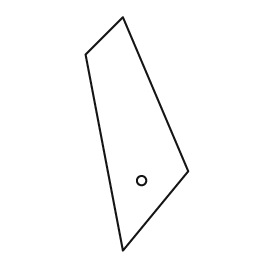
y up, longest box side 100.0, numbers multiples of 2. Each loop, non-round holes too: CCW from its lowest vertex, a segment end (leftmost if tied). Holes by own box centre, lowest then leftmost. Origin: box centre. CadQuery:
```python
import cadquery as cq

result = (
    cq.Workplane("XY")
    .moveTo(-6.0, -50.0)
    .lineTo(22.0, -16.0)
    .lineTo(-6.0, 50.0)
    .lineTo(-22.0, 34.0)
    .close()
    .moveTo(2.0, -20.0)
    .circle(2.0)
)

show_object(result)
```